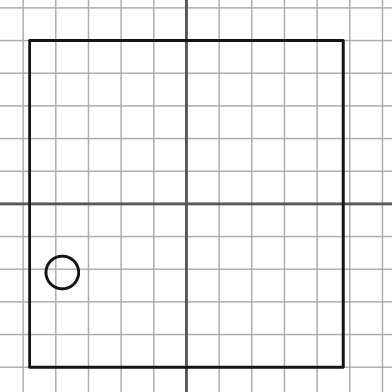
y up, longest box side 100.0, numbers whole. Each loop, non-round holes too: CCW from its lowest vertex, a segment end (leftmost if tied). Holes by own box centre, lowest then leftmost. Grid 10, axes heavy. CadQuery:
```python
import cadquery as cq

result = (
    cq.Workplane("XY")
    .moveTo(-48.0, -50.0)
    .lineTo(48.0, -50.0)
    .lineTo(48.0, 50.0)
    .lineTo(-48.0, 50.0)
    .close()
    .moveTo(-38.0, -21.0)
    .circle(5.0)
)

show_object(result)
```